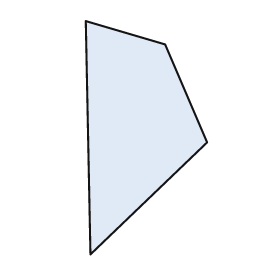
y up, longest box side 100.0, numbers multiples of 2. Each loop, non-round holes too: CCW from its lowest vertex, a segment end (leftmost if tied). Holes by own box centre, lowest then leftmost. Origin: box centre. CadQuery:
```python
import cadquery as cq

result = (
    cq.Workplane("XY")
    .moveTo(-24.0, -50.0)
    .lineTo(26.0, -2.0)
    .lineTo(8.0, 40.0)
    .lineTo(-26.0, 50.0)
    .close()
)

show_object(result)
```